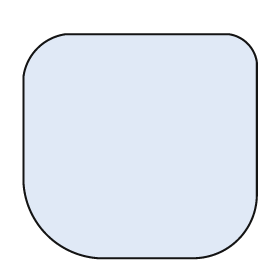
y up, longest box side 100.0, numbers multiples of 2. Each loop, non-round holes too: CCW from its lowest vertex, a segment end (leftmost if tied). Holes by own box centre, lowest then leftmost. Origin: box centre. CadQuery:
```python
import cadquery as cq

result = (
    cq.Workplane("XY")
    .moveTo(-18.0, -48.0)
    .lineTo(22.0, -48.0)
    .threePointArc((42.0, -40.0), (50.0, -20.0))
    .lineTo(50.0, 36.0)
    .threePointArc((46.0, 44.0), (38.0, 48.0))
    .lineTo(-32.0, 48.0)
    .threePointArc((-44.0, 42.0), (-50.0, 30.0))
    .lineTo(-50.0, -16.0)
    .threePointArc((-40.0, -38.0), (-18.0, -48.0))
    .close()
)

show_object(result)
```